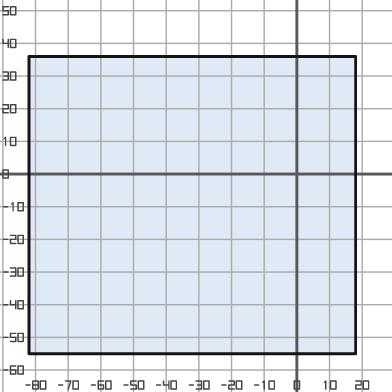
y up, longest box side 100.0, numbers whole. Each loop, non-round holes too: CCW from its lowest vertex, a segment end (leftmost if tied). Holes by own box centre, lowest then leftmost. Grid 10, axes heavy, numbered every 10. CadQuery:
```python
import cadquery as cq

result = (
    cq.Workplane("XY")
    .moveTo(-82.0, -55.0)
    .lineTo(18.0, -55.0)
    .lineTo(18.0, 36.0)
    .lineTo(-82.0, 36.0)
    .close()
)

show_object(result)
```